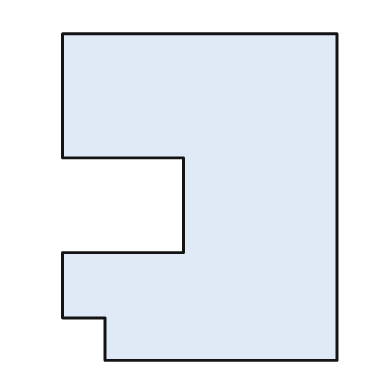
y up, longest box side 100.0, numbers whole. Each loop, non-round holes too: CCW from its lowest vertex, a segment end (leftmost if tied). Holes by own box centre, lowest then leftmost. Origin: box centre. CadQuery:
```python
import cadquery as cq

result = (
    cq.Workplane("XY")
    .moveTo(-29.0, -50.0)
    .lineTo(42.0, -50.0)
    .lineTo(42.0, 50.0)
    .lineTo(-42.0, 50.0)
    .lineTo(-42.0, 12.0)
    .lineTo(-5.0, 12.0)
    .lineTo(-5.0, -17.0)
    .lineTo(-42.0, -17.0)
    .lineTo(-42.0, -37.0)
    .lineTo(-29.0, -37.0)
    .close()
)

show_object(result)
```